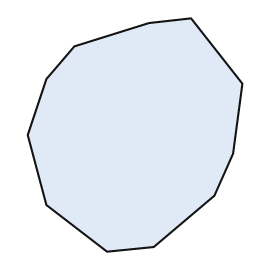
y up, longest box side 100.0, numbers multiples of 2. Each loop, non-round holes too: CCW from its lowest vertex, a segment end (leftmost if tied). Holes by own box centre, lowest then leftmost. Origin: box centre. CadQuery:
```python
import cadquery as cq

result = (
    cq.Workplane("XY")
    .moveTo(-12.0, -50.0)
    .lineTo(8.0, -48.0)
    .lineTo(34.0, -26.0)
    .lineTo(42.0, -8.0)
    .lineTo(46.0, 22.0)
    .lineTo(24.0, 50.0)
    .lineTo(6.0, 48.0)
    .lineTo(-26.0, 38.0)
    .lineTo(-38.0, 24.0)
    .lineTo(-46.0, 0.0)
    .lineTo(-38.0, -30.0)
    .close()
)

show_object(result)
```